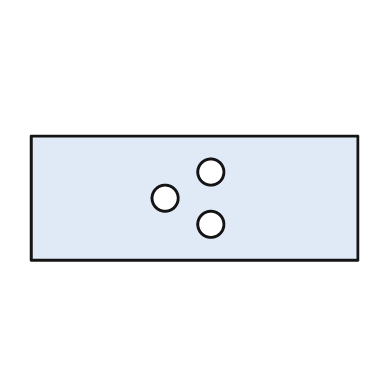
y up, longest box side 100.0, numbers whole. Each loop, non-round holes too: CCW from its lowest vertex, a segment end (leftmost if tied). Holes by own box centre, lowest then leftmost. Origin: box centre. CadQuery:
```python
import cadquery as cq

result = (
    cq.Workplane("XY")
    .moveTo(-50.0, -19.0)
    .lineTo(50.0, -19.0)
    .lineTo(50.0, 19.0)
    .lineTo(-50.0, 19.0)
    .close()
    .moveTo(5.0, -8.0)
    .circle(4.0)
    .moveTo(-9.0, 0.0)
    .circle(4.0)
    .moveTo(5.0, 8.0)
    .circle(4.0)
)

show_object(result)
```